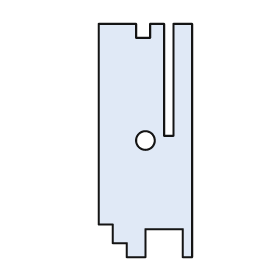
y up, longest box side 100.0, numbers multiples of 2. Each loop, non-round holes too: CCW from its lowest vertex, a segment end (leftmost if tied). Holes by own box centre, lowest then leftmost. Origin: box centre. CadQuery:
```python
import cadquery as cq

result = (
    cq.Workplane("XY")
    .moveTo(-8.0, -50.0)
    .lineTo(0.0, -50.0)
    .lineTo(0.0, -38.0)
    .lineTo(16.0, -38.0)
    .lineTo(16.0, -50.0)
    .lineTo(20.0, -50.0)
    .lineTo(20.0, 50.0)
    .lineTo(12.0, 50.0)
    .lineTo(12.0, 2.0)
    .lineTo(8.0, 2.0)
    .lineTo(8.0, 50.0)
    .lineTo(2.0, 50.0)
    .lineTo(2.0, 44.0)
    .lineTo(-4.0, 44.0)
    .lineTo(-4.0, 50.0)
    .lineTo(-20.0, 50.0)
    .lineTo(-20.0, -36.0)
    .lineTo(-14.0, -36.0)
    .lineTo(-14.0, -44.0)
    .lineTo(-8.0, -44.0)
    .close()
    .moveTo(0.0, 0.0)
    .circle(4.0)
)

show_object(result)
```